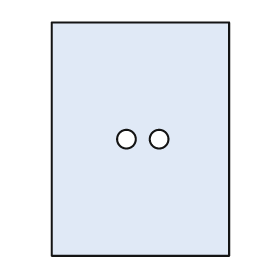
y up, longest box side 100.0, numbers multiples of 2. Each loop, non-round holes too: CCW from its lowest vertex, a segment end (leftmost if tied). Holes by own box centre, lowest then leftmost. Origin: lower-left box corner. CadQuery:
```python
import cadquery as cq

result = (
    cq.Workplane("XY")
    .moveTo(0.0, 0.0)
    .lineTo(76.0, 0.0)
    .lineTo(76.0, 100.0)
    .lineTo(0.0, 100.0)
    .close()
    .moveTo(32.0, 50.0)
    .circle(4.0)
    .moveTo(46.0, 50.0)
    .circle(4.0)
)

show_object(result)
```